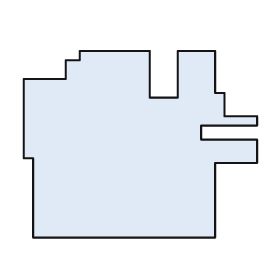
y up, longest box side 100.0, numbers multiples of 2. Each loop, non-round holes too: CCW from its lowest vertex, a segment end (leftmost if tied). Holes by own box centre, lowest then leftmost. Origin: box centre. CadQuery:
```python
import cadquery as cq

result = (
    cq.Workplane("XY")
    .moveTo(-46.0, -40.0)
    .lineTo(32.0, -40.0)
    .lineTo(32.0, -8.0)
    .lineTo(50.0, -8.0)
    .lineTo(50.0, 2.0)
    .lineTo(26.0, 2.0)
    .lineTo(26.0, 8.0)
    .lineTo(50.0, 8.0)
    .lineTo(50.0, 12.0)
    .lineTo(36.0, 12.0)
    .lineTo(36.0, 22.0)
    .lineTo(32.0, 22.0)
    .lineTo(32.0, 40.0)
    .lineTo(16.0, 40.0)
    .lineTo(16.0, 20.0)
    .lineTo(4.0, 20.0)
    .lineTo(4.0, 40.0)
    .lineTo(-26.0, 40.0)
    .lineTo(-26.0, 36.0)
    .lineTo(-32.0, 36.0)
    .lineTo(-32.0, 28.0)
    .lineTo(-50.0, 28.0)
    .lineTo(-50.0, -6.0)
    .lineTo(-46.0, -6.0)
    .close()
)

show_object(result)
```